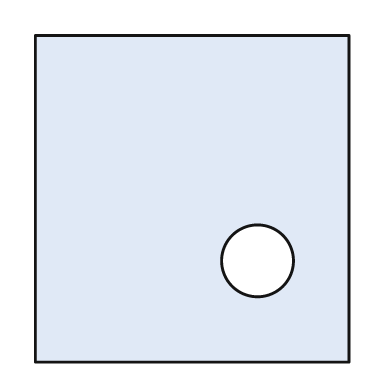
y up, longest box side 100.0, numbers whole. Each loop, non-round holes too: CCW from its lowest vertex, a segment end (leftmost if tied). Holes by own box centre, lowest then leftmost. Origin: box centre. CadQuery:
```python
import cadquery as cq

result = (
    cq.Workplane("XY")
    .moveTo(-48.0, -50.0)
    .lineTo(48.0, -50.0)
    .lineTo(48.0, 50.0)
    .lineTo(-48.0, 50.0)
    .close()
    .moveTo(20.0, -19.0)
    .circle(11.0)
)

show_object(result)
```